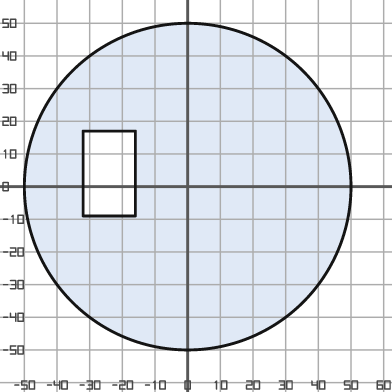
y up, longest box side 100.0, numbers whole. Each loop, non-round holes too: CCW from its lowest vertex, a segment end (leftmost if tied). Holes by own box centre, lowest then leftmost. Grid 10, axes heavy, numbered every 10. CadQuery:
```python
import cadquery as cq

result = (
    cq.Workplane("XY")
    .moveTo(0.0, 0.0)
    .circle(50.0)
    .moveTo(-32.0, -9.0)
    .lineTo(-16.0, -9.0)
    .lineTo(-16.0, 17.0)
    .lineTo(-32.0, 17.0)
    .close()
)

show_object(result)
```